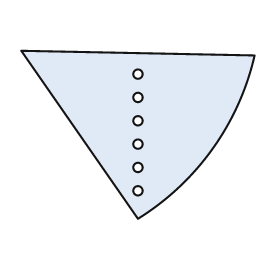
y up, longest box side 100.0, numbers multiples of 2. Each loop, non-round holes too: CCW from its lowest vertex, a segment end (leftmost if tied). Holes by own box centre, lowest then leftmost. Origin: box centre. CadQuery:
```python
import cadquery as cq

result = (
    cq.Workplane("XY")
    .moveTo(0.0, -36.0)
    .threePointArc((32.0, -6.0), (50.0, 34.0))
    .lineTo(-50.0, 36.0)
    .close()
    .moveTo(0.0, -24.0)
    .circle(2.0)
    .moveTo(0.0, -14.0)
    .circle(2.0)
    .moveTo(0.0, -4.0)
    .circle(2.0)
    .moveTo(0.0, 6.0)
    .circle(2.0)
    .moveTo(0.0, 16.0)
    .circle(2.0)
    .moveTo(0.0, 26.0)
    .circle(2.0)
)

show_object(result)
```